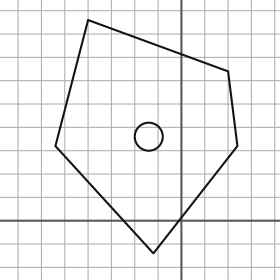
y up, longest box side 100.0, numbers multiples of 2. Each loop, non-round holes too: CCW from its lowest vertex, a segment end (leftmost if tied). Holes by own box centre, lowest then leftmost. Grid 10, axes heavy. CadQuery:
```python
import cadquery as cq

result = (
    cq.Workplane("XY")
    .moveTo(-12.0, -14.0)
    .lineTo(24.0, 32.0)
    .lineTo(20.0, 64.0)
    .lineTo(-40.0, 86.0)
    .lineTo(-54.0, 32.0)
    .close()
    .moveTo(-14.0, 36.0)
    .circle(6.0)
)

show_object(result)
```